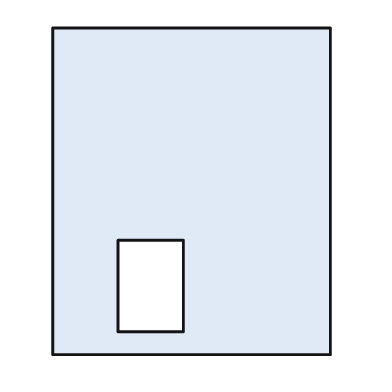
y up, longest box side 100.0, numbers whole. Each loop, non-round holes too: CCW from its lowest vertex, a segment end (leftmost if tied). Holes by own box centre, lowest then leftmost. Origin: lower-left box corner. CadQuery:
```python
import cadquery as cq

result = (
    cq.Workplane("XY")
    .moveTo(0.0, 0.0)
    .lineTo(85.0, 0.0)
    .lineTo(85.0, 100.0)
    .lineTo(0.0, 100.0)
    .close()
    .moveTo(20.0, 7.0)
    .lineTo(40.0, 7.0)
    .lineTo(40.0, 35.0)
    .lineTo(20.0, 35.0)
    .close()
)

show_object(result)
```